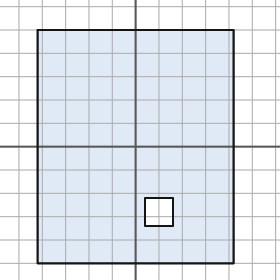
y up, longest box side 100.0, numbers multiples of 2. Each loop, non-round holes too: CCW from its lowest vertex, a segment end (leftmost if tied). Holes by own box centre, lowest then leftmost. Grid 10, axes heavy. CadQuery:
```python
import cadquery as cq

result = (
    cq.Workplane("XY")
    .moveTo(-42.0, -50.0)
    .lineTo(42.0, -50.0)
    .lineTo(42.0, 50.0)
    .lineTo(-42.0, 50.0)
    .close()
    .moveTo(4.0, -34.0)
    .lineTo(16.0, -34.0)
    .lineTo(16.0, -22.0)
    .lineTo(4.0, -22.0)
    .close()
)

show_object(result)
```